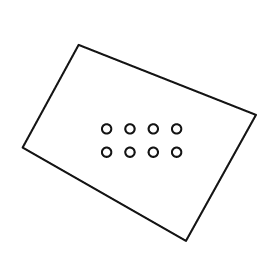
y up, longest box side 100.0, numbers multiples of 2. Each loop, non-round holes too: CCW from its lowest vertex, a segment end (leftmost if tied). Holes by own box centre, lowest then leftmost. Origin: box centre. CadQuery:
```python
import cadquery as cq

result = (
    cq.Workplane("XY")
    .moveTo(20.0, -42.0)
    .lineTo(50.0, 12.0)
    .lineTo(-26.0, 42.0)
    .lineTo(-50.0, -2.0)
    .close()
    .moveTo(-14.0, -4.0)
    .circle(2.0)
    .moveTo(-4.0, -4.0)
    .circle(2.0)
    .moveTo(6.0, -4.0)
    .circle(2.0)
    .moveTo(16.0, -4.0)
    .circle(2.0)
    .moveTo(-14.0, 6.0)
    .circle(2.0)
    .moveTo(-4.0, 6.0)
    .circle(2.0)
    .moveTo(6.0, 6.0)
    .circle(2.0)
    .moveTo(16.0, 6.0)
    .circle(2.0)
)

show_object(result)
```